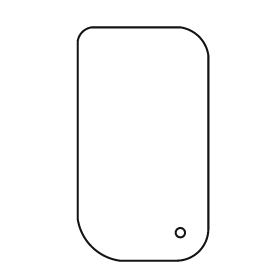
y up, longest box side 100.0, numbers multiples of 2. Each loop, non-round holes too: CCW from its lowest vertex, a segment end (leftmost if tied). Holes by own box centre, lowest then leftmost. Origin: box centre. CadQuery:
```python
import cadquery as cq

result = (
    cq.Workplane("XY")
    .moveTo(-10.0, -50.0)
    .lineTo(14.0, -50.0)
    .threePointArc((24.0, -46.0), (28.0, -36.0))
    .lineTo(28.0, 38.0)
    .threePointArc((24.0, 46.0), (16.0, 50.0))
    .lineTo(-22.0, 50.0)
    .threePointArc((-26.0, 48.0), (-28.0, 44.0))
    .lineTo(-28.0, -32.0)
    .threePointArc((-22.0, -44.0), (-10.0, -50.0))
    .close()
    .moveTo(16.0, -38.0)
    .circle(2.0)
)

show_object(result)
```